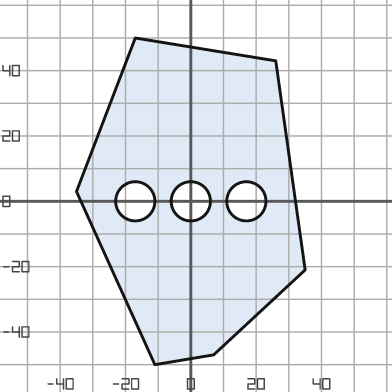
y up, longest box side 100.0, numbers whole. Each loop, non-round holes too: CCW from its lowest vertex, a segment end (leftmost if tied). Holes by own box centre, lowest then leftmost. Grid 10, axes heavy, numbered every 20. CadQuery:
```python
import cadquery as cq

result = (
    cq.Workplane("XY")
    .moveTo(-11.0, -50.0)
    .lineTo(7.0, -47.0)
    .lineTo(35.0, -21.0)
    .lineTo(26.0, 43.0)
    .lineTo(-17.0, 50.0)
    .lineTo(-35.0, 3.0)
    .close()
    .moveTo(-17.0, 0.0)
    .circle(6.0)
    .moveTo(0.0, 0.0)
    .circle(6.0)
    .moveTo(17.0, 0.0)
    .circle(6.0)
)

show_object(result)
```